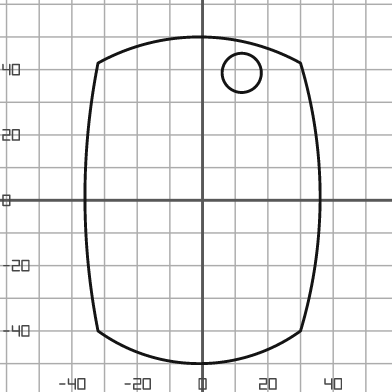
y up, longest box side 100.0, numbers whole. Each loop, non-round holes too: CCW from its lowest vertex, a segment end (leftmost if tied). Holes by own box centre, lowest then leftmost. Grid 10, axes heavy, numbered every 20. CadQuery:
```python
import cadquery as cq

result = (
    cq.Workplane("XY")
    .moveTo(-32.0, -40.0)
    .threePointArc((-1.0, -50.0), (30.0, -40.0))
    .threePointArc((36.0, 1.0), (30.0, 42.0))
    .threePointArc((-1.0, 50.0), (-32.0, 42.0))
    .threePointArc((-36.0, 1.0), (-32.0, -40.0))
    .close()
    .moveTo(12.0, 39.0)
    .circle(6.0)
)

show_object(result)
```